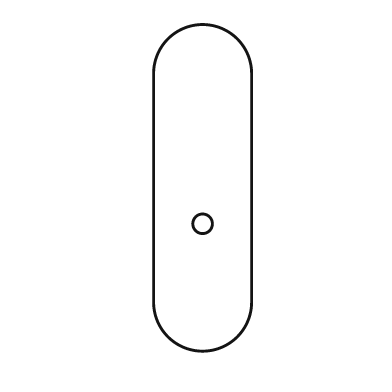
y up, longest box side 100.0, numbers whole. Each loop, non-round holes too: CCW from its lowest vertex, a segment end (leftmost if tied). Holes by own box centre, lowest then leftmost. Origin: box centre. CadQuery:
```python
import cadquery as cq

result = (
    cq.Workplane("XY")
    .moveTo(-15.0, -35.0)
    .threePointArc((0.0, -50.0), (15.0, -35.0))
    .lineTo(15.0, 35.0)
    .threePointArc((0.0, 50.0), (-15.0, 35.0))
    .close()
    .moveTo(0.0, -11.0)
    .circle(3.0)
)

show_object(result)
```